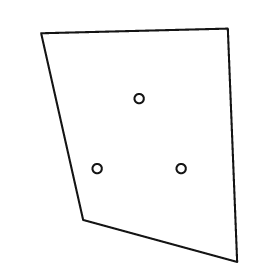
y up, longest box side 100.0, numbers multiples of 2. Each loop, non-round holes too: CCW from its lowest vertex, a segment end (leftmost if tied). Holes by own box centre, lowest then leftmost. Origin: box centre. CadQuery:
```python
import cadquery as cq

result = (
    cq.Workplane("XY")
    .moveTo(42.0, -50.0)
    .lineTo(38.0, 50.0)
    .lineTo(-42.0, 48.0)
    .lineTo(-24.0, -32.0)
    .close()
    .moveTo(-18.0, -10.0)
    .circle(2.0)
    .moveTo(18.0, -10.0)
    .circle(2.0)
    .moveTo(0.0, 20.0)
    .circle(2.0)
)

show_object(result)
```